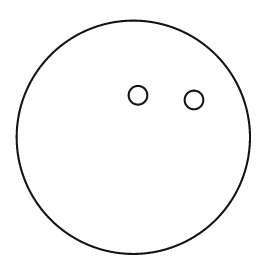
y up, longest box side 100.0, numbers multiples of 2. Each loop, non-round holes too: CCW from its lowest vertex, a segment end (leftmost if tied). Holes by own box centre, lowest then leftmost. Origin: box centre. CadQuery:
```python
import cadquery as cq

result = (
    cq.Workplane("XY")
    .moveTo(0.0, 0.0)
    .circle(50.0)
    .moveTo(26.0, 16.0)
    .circle(4.0)
    .moveTo(2.0, 18.0)
    .circle(4.0)
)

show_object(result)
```